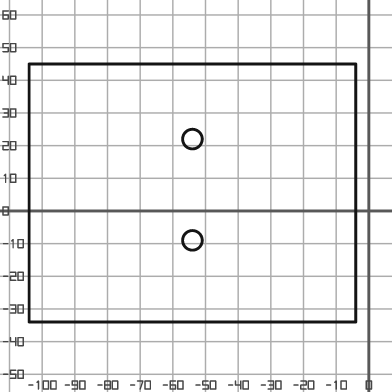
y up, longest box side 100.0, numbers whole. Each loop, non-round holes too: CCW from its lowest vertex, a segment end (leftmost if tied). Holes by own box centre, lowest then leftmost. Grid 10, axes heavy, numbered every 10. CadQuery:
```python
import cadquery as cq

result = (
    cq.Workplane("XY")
    .moveTo(-104.0, -34.0)
    .lineTo(-4.0, -34.0)
    .lineTo(-4.0, 45.0)
    .lineTo(-104.0, 45.0)
    .close()
    .moveTo(-54.0, -9.0)
    .circle(3.0)
    .moveTo(-54.0, 22.0)
    .circle(3.0)
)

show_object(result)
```